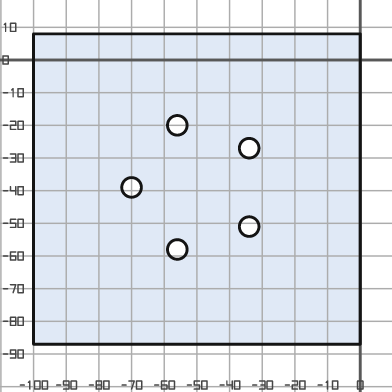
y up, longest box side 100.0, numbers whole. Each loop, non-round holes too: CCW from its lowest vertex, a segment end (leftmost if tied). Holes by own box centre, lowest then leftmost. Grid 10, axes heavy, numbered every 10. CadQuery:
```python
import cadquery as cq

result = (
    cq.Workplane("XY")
    .moveTo(-100.0, -87.0)
    .lineTo(0.0, -87.0)
    .lineTo(0.0, 8.0)
    .lineTo(-100.0, 8.0)
    .close()
    .moveTo(-56.0, -58.0)
    .circle(3.0)
    .moveTo(-34.0, -51.0)
    .circle(3.0)
    .moveTo(-70.0, -39.0)
    .circle(3.0)
    .moveTo(-34.0, -27.0)
    .circle(3.0)
    .moveTo(-56.0, -20.0)
    .circle(3.0)
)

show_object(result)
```